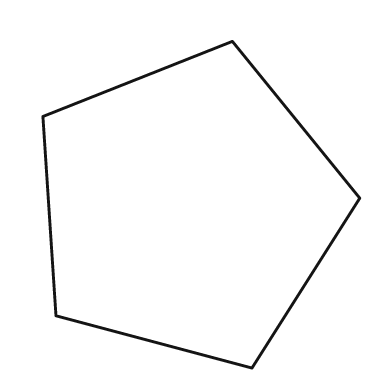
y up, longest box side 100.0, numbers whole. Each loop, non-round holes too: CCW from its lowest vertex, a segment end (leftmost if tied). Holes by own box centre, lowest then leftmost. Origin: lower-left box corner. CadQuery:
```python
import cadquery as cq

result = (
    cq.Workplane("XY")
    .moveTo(64.0, 0.0)
    .lineTo(97.0, 52.0)
    .lineTo(58.0, 100.0)
    .lineTo(0.0, 77.0)
    .lineTo(4.0, 16.0)
    .close()
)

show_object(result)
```